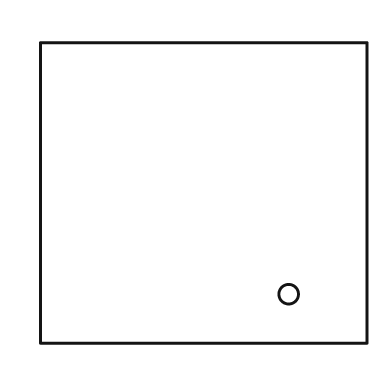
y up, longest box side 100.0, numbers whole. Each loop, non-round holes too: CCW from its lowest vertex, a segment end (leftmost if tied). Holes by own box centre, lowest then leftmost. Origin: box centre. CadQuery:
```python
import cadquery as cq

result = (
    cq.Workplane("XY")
    .moveTo(-50.0, -46.0)
    .lineTo(50.0, -46.0)
    .lineTo(50.0, 46.0)
    .lineTo(-50.0, 46.0)
    .close()
    .moveTo(26.0, -31.0)
    .circle(3.0)
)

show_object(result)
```